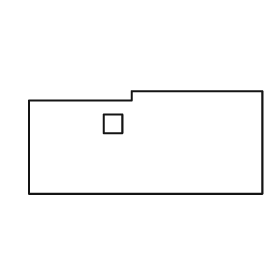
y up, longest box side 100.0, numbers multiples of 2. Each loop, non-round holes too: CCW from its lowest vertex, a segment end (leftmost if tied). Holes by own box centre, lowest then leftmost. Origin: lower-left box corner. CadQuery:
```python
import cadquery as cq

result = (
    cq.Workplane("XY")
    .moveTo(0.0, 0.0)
    .lineTo(100.0, 0.0)
    .lineTo(100.0, 44.0)
    .lineTo(44.0, 44.0)
    .lineTo(44.0, 40.0)
    .lineTo(0.0, 40.0)
    .close()
    .moveTo(32.0, 26.0)
    .lineTo(40.0, 26.0)
    .lineTo(40.0, 34.0)
    .lineTo(32.0, 34.0)
    .close()
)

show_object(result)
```